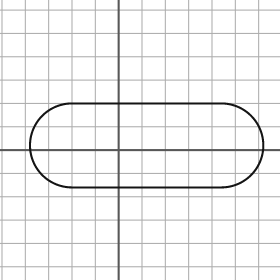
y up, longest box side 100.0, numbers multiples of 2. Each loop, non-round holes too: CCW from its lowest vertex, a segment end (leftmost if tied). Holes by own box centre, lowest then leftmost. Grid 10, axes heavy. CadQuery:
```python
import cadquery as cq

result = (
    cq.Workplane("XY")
    .moveTo(-20.0, -16.0)
    .lineTo(44.0, -16.0)
    .threePointArc((62.0, 2.0), (44.0, 20.0))
    .lineTo(-20.0, 20.0)
    .threePointArc((-38.0, 2.0), (-20.0, -16.0))
    .close()
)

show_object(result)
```